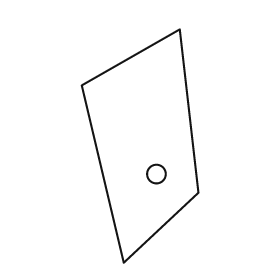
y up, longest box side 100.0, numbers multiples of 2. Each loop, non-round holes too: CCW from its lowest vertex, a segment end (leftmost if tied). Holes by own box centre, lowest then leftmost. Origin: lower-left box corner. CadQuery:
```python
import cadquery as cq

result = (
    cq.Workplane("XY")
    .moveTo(18.0, 0.0)
    .lineTo(50.0, 30.0)
    .lineTo(42.0, 100.0)
    .lineTo(0.0, 76.0)
    .close()
    .moveTo(32.0, 38.0)
    .circle(4.0)
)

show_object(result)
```